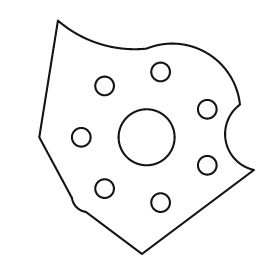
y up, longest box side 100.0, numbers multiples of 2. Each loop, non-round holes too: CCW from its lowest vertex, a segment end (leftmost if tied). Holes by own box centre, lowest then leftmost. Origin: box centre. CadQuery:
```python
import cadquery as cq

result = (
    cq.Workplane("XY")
    .moveTo(-2.0, -50.0)
    .lineTo(46.0, -14.0)
    .threePointArc((34.0, -2.0), (40.0, 14.0))
    .threePointArc((26.0, 36.0), (0.0, 38.0))
    .threePointArc((-20.0, 40.0), (-38.0, 50.0))
    .lineTo(-46.0, 0.0)
    .lineTo(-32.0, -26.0)
    .threePointArc((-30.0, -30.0), (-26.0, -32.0))
    .close()
    .moveTo(6.0, -28.0)
    .circle(4.0)
    .moveTo(-18.0, -22.0)
    .circle(4.0)
    .moveTo(26.0, -12.0)
    .circle(4.0)
    .moveTo(-28.0, 0.0)
    .circle(4.0)
    .moveTo(0.0, 0.0)
    .circle(12.0)
    .moveTo(26.0, 12.0)
    .circle(4.0)
    .moveTo(-18.0, 22.0)
    .circle(4.0)
    .moveTo(6.0, 28.0)
    .circle(4.0)
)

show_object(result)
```